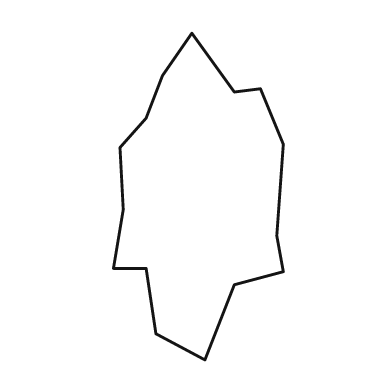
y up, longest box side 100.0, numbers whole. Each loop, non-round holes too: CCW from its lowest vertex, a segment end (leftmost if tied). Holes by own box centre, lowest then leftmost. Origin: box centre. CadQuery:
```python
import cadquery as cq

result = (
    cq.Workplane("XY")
    .moveTo(2.0, -50.0)
    .lineTo(11.0, -27.0)
    .lineTo(26.0, -23.0)
    .lineTo(24.0, -12.0)
    .lineTo(26.0, 16.0)
    .lineTo(19.0, 33.0)
    .lineTo(11.0, 32.0)
    .lineTo(-2.0, 50.0)
    .lineTo(-11.0, 37.0)
    .lineTo(-16.0, 24.0)
    .lineTo(-24.0, 15.0)
    .lineTo(-23.0, -4.0)
    .lineTo(-26.0, -22.0)
    .lineTo(-16.0, -22.0)
    .lineTo(-13.0, -42.0)
    .close()
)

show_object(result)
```